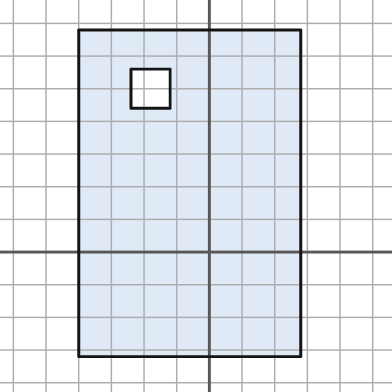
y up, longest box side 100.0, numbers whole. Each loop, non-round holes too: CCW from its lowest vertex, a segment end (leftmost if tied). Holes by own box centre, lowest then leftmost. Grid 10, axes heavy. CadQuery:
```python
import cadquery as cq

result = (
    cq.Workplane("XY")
    .moveTo(-40.0, -32.0)
    .lineTo(28.0, -32.0)
    .lineTo(28.0, 68.0)
    .lineTo(-40.0, 68.0)
    .close()
    .moveTo(-24.0, 44.0)
    .lineTo(-12.0, 44.0)
    .lineTo(-12.0, 56.0)
    .lineTo(-24.0, 56.0)
    .close()
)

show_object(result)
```